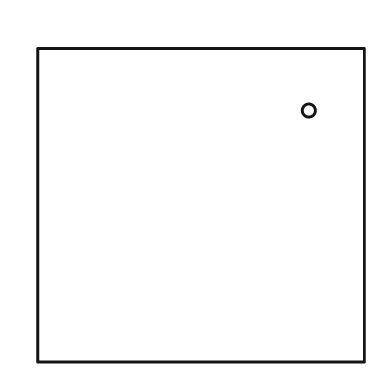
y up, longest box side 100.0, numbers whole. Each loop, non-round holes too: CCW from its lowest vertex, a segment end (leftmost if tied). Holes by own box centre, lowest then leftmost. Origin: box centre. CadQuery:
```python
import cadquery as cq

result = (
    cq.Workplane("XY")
    .moveTo(-50.0, -48.0)
    .lineTo(50.0, -48.0)
    .lineTo(50.0, 48.0)
    .lineTo(-50.0, 48.0)
    .close()
    .moveTo(33.0, 29.0)
    .circle(2.0)
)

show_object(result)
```